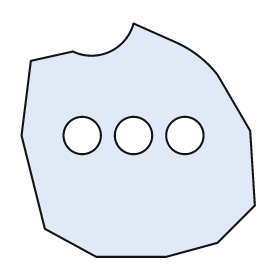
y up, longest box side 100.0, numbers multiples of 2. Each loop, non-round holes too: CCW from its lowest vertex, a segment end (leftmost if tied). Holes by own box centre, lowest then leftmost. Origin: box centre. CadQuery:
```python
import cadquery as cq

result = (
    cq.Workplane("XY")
    .moveTo(-18.0, -50.0)
    .lineTo(12.0, -50.0)
    .lineTo(34.0, -44.0)
    .lineTo(50.0, -28.0)
    .lineTo(48.0, 4.0)
    .lineTo(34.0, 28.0)
    .threePointArc((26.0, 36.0), (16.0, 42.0))
    .lineTo(-2.0, 50.0)
    .threePointArc((-12.0, 38.0), (-28.0, 38.0))
    .lineTo(-46.0, 34.0)
    .lineTo(-50.0, 2.0)
    .lineTo(-40.0, -38.0)
    .close()
    .moveTo(-24.0, 2.0)
    .circle(8.0)
    .moveTo(-2.0, 2.0)
    .circle(8.0)
    .moveTo(20.0, 2.0)
    .circle(8.0)
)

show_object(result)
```